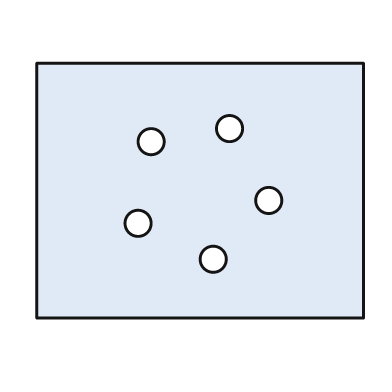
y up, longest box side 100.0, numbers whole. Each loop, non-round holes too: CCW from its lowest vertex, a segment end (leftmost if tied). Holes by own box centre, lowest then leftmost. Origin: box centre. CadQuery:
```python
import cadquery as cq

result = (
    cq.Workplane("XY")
    .moveTo(-50.0, -39.0)
    .lineTo(50.0, -39.0)
    .lineTo(50.0, 39.0)
    .lineTo(-50.0, 39.0)
    .close()
    .moveTo(4.0, -21.0)
    .circle(4.0)
    .moveTo(-19.0, -10.0)
    .circle(4.0)
    .moveTo(21.0, -3.0)
    .circle(4.0)
    .moveTo(-15.0, 15.0)
    .circle(4.0)
    .moveTo(9.0, 19.0)
    .circle(4.0)
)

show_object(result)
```